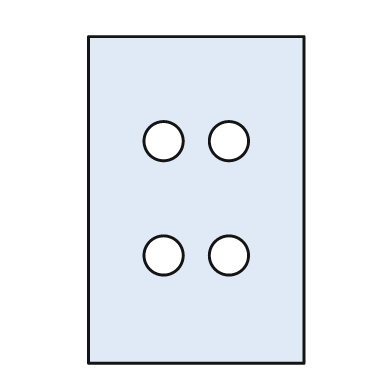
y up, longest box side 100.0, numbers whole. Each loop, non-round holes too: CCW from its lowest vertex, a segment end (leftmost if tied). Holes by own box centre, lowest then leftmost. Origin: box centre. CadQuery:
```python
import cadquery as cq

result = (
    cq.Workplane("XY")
    .moveTo(-33.0, -50.0)
    .lineTo(33.0, -50.0)
    .lineTo(33.0, 50.0)
    .lineTo(-33.0, 50.0)
    .close()
    .moveTo(-10.0, -17.0)
    .circle(6.0)
    .moveTo(10.0, -17.0)
    .circle(6.0)
    .moveTo(-10.0, 18.0)
    .circle(6.0)
    .moveTo(10.0, 18.0)
    .circle(6.0)
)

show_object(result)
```